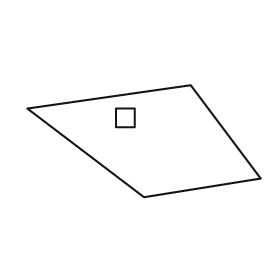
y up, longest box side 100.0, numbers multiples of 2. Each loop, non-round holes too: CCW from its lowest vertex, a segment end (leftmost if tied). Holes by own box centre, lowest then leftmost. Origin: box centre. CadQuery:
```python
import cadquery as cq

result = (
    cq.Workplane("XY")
    .moveTo(0.0, -24.0)
    .lineTo(50.0, -16.0)
    .lineTo(20.0, 24.0)
    .lineTo(-50.0, 14.0)
    .close()
    .moveTo(-12.0, 6.0)
    .lineTo(-4.0, 6.0)
    .lineTo(-4.0, 14.0)
    .lineTo(-12.0, 14.0)
    .close()
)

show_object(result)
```